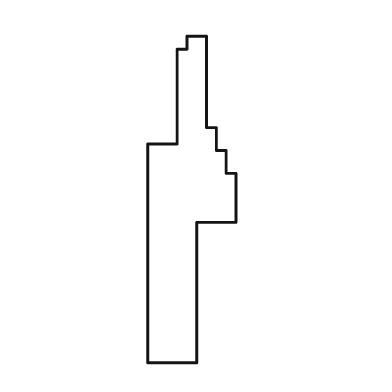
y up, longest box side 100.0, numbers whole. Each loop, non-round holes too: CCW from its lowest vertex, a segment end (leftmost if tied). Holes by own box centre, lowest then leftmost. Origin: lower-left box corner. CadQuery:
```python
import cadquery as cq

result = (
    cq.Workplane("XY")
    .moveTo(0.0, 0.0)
    .lineTo(15.0, 0.0)
    .lineTo(15.0, 43.0)
    .lineTo(27.0, 43.0)
    .lineTo(27.0, 58.0)
    .lineTo(24.0, 58.0)
    .lineTo(24.0, 65.0)
    .lineTo(21.0, 65.0)
    .lineTo(21.0, 72.0)
    .lineTo(18.0, 72.0)
    .lineTo(18.0, 100.0)
    .lineTo(12.0, 100.0)
    .lineTo(12.0, 96.0)
    .lineTo(9.0, 96.0)
    .lineTo(9.0, 67.0)
    .lineTo(0.0, 67.0)
    .close()
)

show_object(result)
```